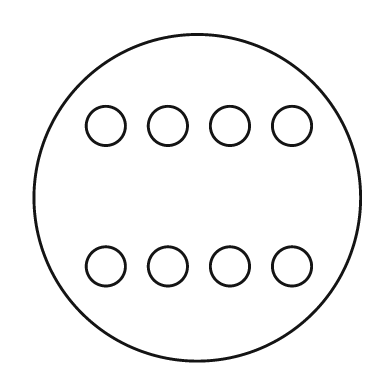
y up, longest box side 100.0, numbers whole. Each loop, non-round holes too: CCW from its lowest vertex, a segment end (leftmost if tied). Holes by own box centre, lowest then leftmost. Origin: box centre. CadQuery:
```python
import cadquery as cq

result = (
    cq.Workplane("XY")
    .moveTo(0.0, 0.0)
    .circle(50.0)
    .moveTo(-28.0, -21.0)
    .circle(6.0)
    .moveTo(-9.0, -21.0)
    .circle(6.0)
    .moveTo(10.0, -21.0)
    .circle(6.0)
    .moveTo(29.0, -21.0)
    .circle(6.0)
    .moveTo(-28.0, 22.0)
    .circle(6.0)
    .moveTo(-9.0, 22.0)
    .circle(6.0)
    .moveTo(10.0, 22.0)
    .circle(6.0)
    .moveTo(29.0, 22.0)
    .circle(6.0)
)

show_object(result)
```